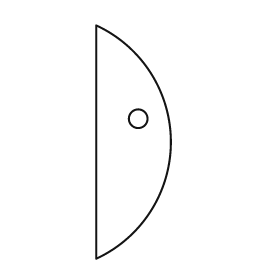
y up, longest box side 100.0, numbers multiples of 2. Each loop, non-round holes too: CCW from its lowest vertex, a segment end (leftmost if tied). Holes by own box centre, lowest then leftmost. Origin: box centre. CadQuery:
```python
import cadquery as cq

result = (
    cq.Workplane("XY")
    .moveTo(-16.0, -50.0)
    .threePointArc((16.0, 0.0), (-16.0, 50.0))
    .close()
    .moveTo(2.0, 10.0)
    .circle(4.0)
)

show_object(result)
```